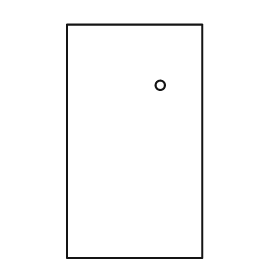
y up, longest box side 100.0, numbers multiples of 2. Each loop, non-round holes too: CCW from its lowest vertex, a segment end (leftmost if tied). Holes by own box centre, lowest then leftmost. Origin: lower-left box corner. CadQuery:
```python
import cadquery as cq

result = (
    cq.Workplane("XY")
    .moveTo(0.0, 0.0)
    .lineTo(58.0, 0.0)
    .lineTo(58.0, 100.0)
    .lineTo(0.0, 100.0)
    .close()
    .moveTo(40.0, 74.0)
    .circle(2.0)
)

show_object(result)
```